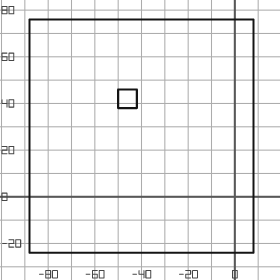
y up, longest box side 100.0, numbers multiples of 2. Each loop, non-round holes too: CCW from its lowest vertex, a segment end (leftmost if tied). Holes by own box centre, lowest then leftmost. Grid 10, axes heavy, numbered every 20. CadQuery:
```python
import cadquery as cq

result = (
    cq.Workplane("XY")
    .moveTo(-88.0, -24.0)
    .lineTo(8.0, -24.0)
    .lineTo(8.0, 76.0)
    .lineTo(-88.0, 76.0)
    .close()
    .moveTo(-50.0, 38.0)
    .lineTo(-42.0, 38.0)
    .lineTo(-42.0, 46.0)
    .lineTo(-50.0, 46.0)
    .close()
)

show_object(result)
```